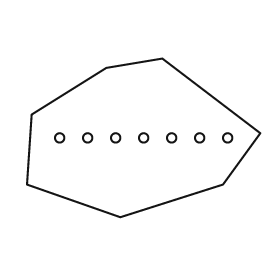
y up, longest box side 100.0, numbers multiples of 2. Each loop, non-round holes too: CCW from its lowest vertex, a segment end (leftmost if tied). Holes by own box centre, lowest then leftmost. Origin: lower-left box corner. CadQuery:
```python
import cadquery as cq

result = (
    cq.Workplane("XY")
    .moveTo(40.0, 0.0)
    .lineTo(84.0, 14.0)
    .lineTo(100.0, 36.0)
    .lineTo(58.0, 68.0)
    .lineTo(34.0, 64.0)
    .lineTo(2.0, 44.0)
    .lineTo(0.0, 14.0)
    .close()
    .moveTo(14.0, 34.0)
    .circle(2.0)
    .moveTo(26.0, 34.0)
    .circle(2.0)
    .moveTo(38.0, 34.0)
    .circle(2.0)
    .moveTo(50.0, 34.0)
    .circle(2.0)
    .moveTo(62.0, 34.0)
    .circle(2.0)
    .moveTo(74.0, 34.0)
    .circle(2.0)
    .moveTo(86.0, 34.0)
    .circle(2.0)
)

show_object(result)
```